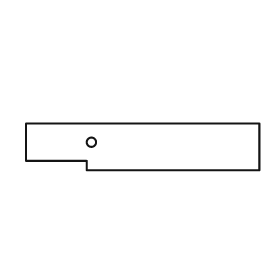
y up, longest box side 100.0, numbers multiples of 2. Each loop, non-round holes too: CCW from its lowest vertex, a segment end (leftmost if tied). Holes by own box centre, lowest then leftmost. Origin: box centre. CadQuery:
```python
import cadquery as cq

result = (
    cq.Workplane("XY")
    .moveTo(-24.0, -10.0)
    .lineTo(50.0, -10.0)
    .lineTo(50.0, 10.0)
    .lineTo(-50.0, 10.0)
    .lineTo(-50.0, -6.0)
    .lineTo(-24.0, -6.0)
    .close()
    .moveTo(-22.0, 2.0)
    .circle(2.0)
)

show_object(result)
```